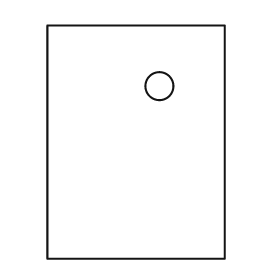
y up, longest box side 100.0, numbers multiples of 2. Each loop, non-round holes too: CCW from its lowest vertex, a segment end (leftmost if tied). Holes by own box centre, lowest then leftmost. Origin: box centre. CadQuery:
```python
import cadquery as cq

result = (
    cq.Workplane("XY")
    .moveTo(-38.0, -50.0)
    .lineTo(38.0, -50.0)
    .lineTo(38.0, 50.0)
    .lineTo(-38.0, 50.0)
    .close()
    .moveTo(10.0, 24.0)
    .circle(6.0)
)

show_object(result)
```